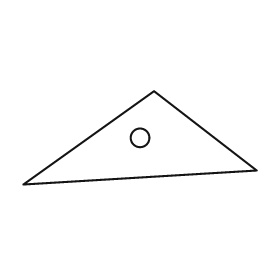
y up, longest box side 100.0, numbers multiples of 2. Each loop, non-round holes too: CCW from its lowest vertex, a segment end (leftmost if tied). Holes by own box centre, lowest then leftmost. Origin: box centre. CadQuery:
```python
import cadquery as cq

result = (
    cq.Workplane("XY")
    .moveTo(-50.0, -20.0)
    .lineTo(50.0, -14.0)
    .lineTo(6.0, 20.0)
    .close()
    .moveTo(0.0, 0.0)
    .circle(4.0)
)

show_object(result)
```